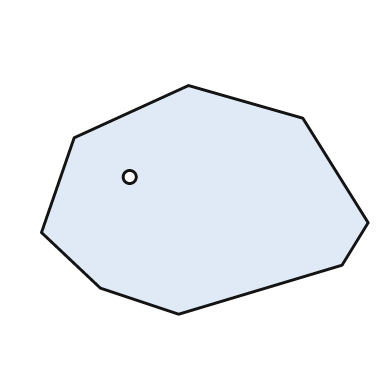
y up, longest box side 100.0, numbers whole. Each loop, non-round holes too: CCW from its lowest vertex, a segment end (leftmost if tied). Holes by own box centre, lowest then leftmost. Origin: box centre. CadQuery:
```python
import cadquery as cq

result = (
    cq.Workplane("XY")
    .moveTo(-8.0, -35.0)
    .lineTo(42.0, -20.0)
    .lineTo(50.0, -7.0)
    .lineTo(30.0, 25.0)
    .lineTo(-5.0, 35.0)
    .lineTo(-40.0, 19.0)
    .lineTo(-50.0, -10.0)
    .lineTo(-32.0, -27.0)
    .close()
    .moveTo(-23.0, 7.0)
    .circle(2.0)
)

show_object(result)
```